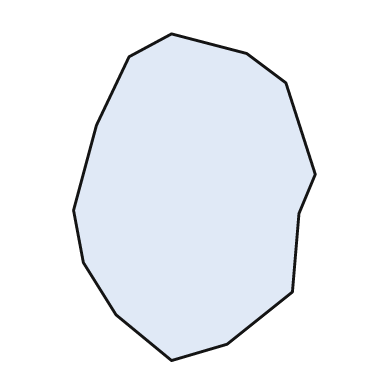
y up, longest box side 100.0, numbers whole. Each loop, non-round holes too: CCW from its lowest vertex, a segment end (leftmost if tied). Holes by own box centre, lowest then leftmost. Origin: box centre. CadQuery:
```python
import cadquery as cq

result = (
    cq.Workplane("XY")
    .moveTo(-7.0, -50.0)
    .lineTo(10.0, -45.0)
    .lineTo(30.0, -29.0)
    .lineTo(32.0, -5.0)
    .lineTo(37.0, 7.0)
    .lineTo(28.0, 35.0)
    .lineTo(16.0, 44.0)
    .lineTo(-7.0, 50.0)
    .lineTo(-20.0, 43.0)
    .lineTo(-30.0, 22.0)
    .lineTo(-37.0, -4.0)
    .lineTo(-34.0, -20.0)
    .lineTo(-24.0, -36.0)
    .close()
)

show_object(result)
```